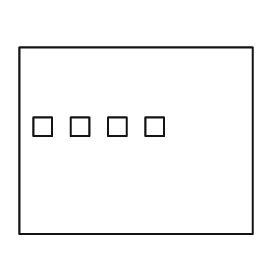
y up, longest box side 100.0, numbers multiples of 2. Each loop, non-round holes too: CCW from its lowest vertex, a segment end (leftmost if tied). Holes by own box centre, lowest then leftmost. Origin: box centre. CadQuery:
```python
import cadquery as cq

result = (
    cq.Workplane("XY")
    .moveTo(-50.0, -40.0)
    .lineTo(50.0, -40.0)
    .lineTo(50.0, 40.0)
    .lineTo(-50.0, 40.0)
    .close()
    .moveTo(-44.0, 2.0)
    .lineTo(-36.0, 2.0)
    .lineTo(-36.0, 10.0)
    .lineTo(-44.0, 10.0)
    .close()
    .moveTo(-28.0, 2.0)
    .lineTo(-20.0, 2.0)
    .lineTo(-20.0, 10.0)
    .lineTo(-28.0, 10.0)
    .close()
    .moveTo(-12.0, 2.0)
    .lineTo(-4.0, 2.0)
    .lineTo(-4.0, 10.0)
    .lineTo(-12.0, 10.0)
    .close()
    .moveTo(4.0, 2.0)
    .lineTo(12.0, 2.0)
    .lineTo(12.0, 10.0)
    .lineTo(4.0, 10.0)
    .close()
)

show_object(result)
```